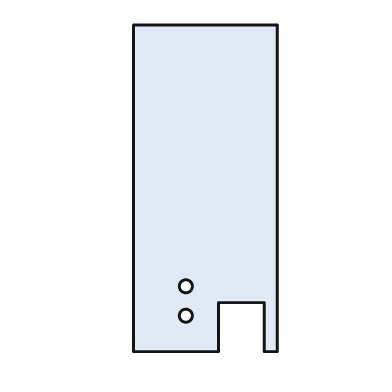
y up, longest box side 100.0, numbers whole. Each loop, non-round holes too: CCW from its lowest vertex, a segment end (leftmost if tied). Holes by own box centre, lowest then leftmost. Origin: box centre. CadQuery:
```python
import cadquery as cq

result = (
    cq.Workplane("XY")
    .moveTo(-22.0, -50.0)
    .lineTo(4.0, -50.0)
    .lineTo(4.0, -35.0)
    .lineTo(18.0, -35.0)
    .lineTo(18.0, -50.0)
    .lineTo(22.0, -50.0)
    .lineTo(22.0, 50.0)
    .lineTo(-22.0, 50.0)
    .close()
    .moveTo(-6.0, -39.0)
    .circle(2.0)
    .moveTo(-6.0, -30.0)
    .circle(2.0)
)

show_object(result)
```